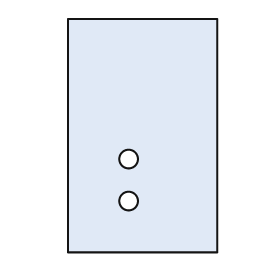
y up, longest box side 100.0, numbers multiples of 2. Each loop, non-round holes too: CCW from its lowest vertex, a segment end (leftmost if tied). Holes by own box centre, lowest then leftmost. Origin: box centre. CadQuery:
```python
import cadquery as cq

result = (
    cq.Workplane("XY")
    .moveTo(-32.0, -50.0)
    .lineTo(32.0, -50.0)
    .lineTo(32.0, 50.0)
    .lineTo(-32.0, 50.0)
    .close()
    .moveTo(-6.0, -28.0)
    .circle(4.0)
    .moveTo(-6.0, -10.0)
    .circle(4.0)
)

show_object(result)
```